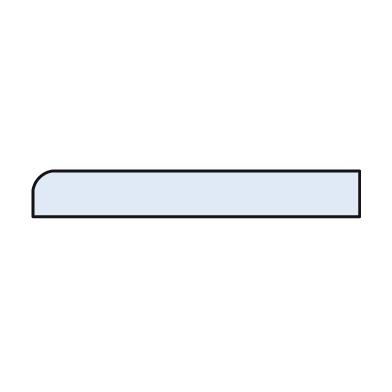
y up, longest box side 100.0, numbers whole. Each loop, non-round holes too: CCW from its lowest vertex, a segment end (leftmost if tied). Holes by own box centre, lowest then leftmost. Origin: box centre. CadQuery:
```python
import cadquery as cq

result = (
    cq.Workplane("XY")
    .moveTo(-50.0, -7.0)
    .lineTo(50.0, -7.0)
    .lineTo(50.0, 7.0)
    .lineTo(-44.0, 7.0)
    .threePointArc((-48.0, 5.0), (-50.0, 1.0))
    .close()
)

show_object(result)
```